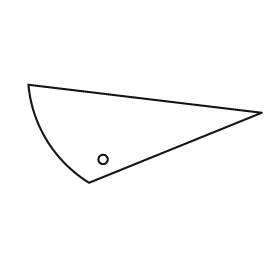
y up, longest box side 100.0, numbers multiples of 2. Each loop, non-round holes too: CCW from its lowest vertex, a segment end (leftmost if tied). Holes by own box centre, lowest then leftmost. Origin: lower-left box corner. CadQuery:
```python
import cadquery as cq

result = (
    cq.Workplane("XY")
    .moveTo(26.0, 0.0)
    .lineTo(100.0, 30.0)
    .lineTo(0.0, 42.0)
    .threePointArc((8.0, 18.0), (26.0, 0.0))
    .close()
    .moveTo(32.0, 10.0)
    .circle(2.0)
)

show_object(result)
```